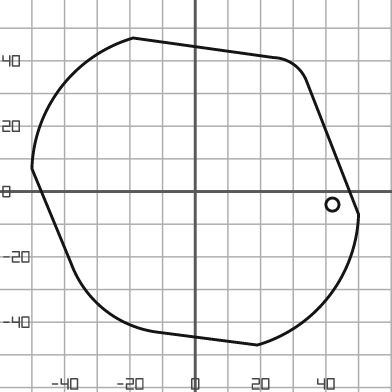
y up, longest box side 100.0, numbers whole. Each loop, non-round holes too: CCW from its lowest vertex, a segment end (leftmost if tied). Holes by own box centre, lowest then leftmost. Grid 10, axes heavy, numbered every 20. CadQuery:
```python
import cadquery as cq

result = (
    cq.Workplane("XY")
    .moveTo(19.0, -47.0)
    .threePointArc((41.0, -32.0), (50.0, -7.0))
    .lineTo(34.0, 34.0)
    .threePointArc((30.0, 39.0), (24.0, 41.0))
    .lineTo(-19.0, 47.0)
    .threePointArc((-41.0, 32.0), (-50.0, 7.0))
    .lineTo(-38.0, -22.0)
    .threePointArc((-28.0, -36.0), (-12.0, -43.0))
    .close()
    .moveTo(42.0, -4.0)
    .circle(2.0)
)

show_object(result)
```